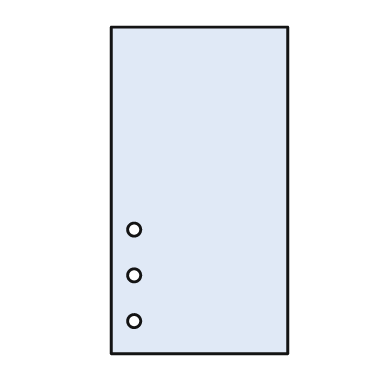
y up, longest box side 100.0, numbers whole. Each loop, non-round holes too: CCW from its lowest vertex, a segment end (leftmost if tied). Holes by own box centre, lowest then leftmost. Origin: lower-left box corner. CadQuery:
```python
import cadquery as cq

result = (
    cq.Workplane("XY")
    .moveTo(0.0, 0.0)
    .lineTo(54.0, 0.0)
    .lineTo(54.0, 100.0)
    .lineTo(0.0, 100.0)
    .close()
    .moveTo(7.0, 10.0)
    .circle(2.0)
    .moveTo(7.0, 24.0)
    .circle(2.0)
    .moveTo(7.0, 38.0)
    .circle(2.0)
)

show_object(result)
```